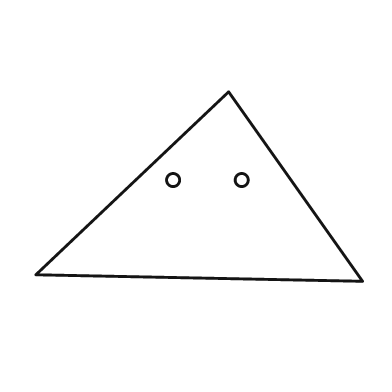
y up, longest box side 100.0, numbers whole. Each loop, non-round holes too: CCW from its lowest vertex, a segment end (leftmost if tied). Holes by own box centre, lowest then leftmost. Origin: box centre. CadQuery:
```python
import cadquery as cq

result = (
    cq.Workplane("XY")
    .moveTo(50.0, -29.0)
    .lineTo(9.0, 29.0)
    .lineTo(-50.0, -27.0)
    .close()
    .moveTo(-8.0, 2.0)
    .circle(2.0)
    .moveTo(13.0, 2.0)
    .circle(2.0)
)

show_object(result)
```